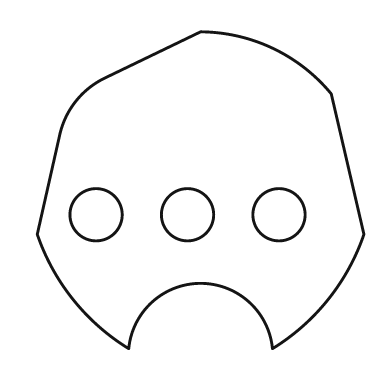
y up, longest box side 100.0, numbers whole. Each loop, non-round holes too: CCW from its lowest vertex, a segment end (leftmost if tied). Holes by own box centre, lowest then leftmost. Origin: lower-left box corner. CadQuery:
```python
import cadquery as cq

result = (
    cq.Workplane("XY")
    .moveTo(28.0, 0.0)
    .threePointArc((50.0, 20.0), (72.0, 0.0))
    .threePointArc((89.0, 15.0), (100.0, 35.0))
    .lineTo(90.0, 78.0)
    .threePointArc((72.0, 92.0), (50.0, 97.0))
    .lineTo(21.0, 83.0)
    .threePointArc((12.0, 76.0), (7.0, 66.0))
    .lineTo(0.0, 35.0)
    .threePointArc((11.0, 15.0), (28.0, 0.0))
    .close()
    .moveTo(18.0, 41.0)
    .circle(8.0)
    .moveTo(46.0, 41.0)
    .circle(8.0)
    .moveTo(74.0, 41.0)
    .circle(8.0)
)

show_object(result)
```